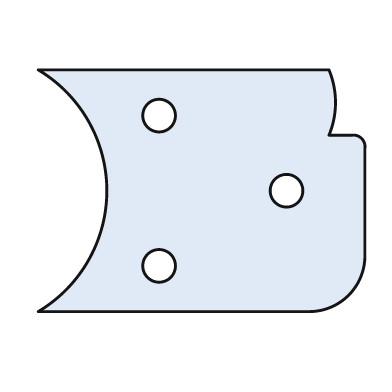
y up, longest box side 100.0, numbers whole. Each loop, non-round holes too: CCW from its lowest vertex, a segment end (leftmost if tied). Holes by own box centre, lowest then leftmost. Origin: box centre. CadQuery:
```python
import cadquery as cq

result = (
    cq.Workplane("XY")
    .moveTo(-50.0, -37.0)
    .lineTo(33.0, -37.0)
    .threePointArc((45.0, -32.0), (50.0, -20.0))
    .lineTo(50.0, 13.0)
    .threePointArc((49.0, 16.0), (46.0, 17.0))
    .lineTo(39.0, 17.0)
    .threePointArc((41.0, 27.0), (39.0, 37.0))
    .lineTo(-50.0, 37.0)
    .threePointArc((-29.0, 0.0), (-50.0, -37.0))
    .close()
    .moveTo(-13.0, -23.0)
    .circle(5.0)
    .moveTo(26.0, 0.0)
    .circle(5.0)
    .moveTo(-13.0, 23.0)
    .circle(5.0)
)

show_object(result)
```